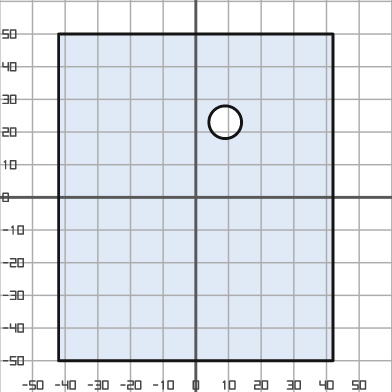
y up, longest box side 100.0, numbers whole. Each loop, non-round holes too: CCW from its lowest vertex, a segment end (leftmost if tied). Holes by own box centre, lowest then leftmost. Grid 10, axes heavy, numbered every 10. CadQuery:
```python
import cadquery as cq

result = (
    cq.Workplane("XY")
    .moveTo(-42.0, -50.0)
    .lineTo(42.0, -50.0)
    .lineTo(42.0, 50.0)
    .lineTo(-42.0, 50.0)
    .close()
    .moveTo(9.0, 23.0)
    .circle(5.0)
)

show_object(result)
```